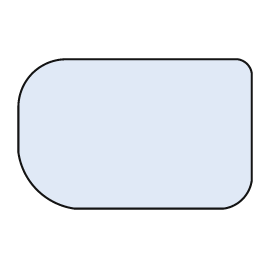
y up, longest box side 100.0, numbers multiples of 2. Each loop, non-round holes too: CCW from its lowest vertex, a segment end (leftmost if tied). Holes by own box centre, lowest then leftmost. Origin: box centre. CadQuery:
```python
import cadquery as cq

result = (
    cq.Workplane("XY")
    .moveTo(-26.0, -32.0)
    .lineTo(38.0, -32.0)
    .threePointArc((46.0, -28.0), (50.0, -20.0))
    .lineTo(50.0, 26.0)
    .threePointArc((48.0, 30.0), (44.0, 32.0))
    .lineTo(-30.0, 32.0)
    .threePointArc((-44.0, 26.0), (-50.0, 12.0))
    .lineTo(-50.0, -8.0)
    .threePointArc((-42.0, -24.0), (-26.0, -32.0))
    .close()
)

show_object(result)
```